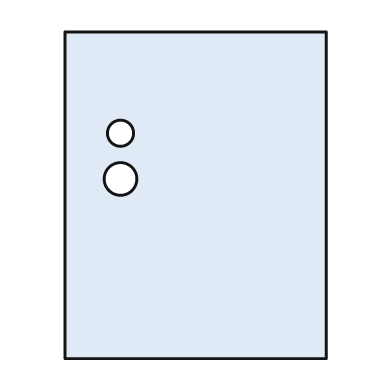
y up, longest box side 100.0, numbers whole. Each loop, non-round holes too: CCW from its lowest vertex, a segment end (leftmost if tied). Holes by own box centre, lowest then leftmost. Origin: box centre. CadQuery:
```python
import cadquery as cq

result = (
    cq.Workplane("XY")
    .moveTo(-40.0, -50.0)
    .lineTo(40.0, -50.0)
    .lineTo(40.0, 50.0)
    .lineTo(-40.0, 50.0)
    .close()
    .moveTo(-23.0, 5.0)
    .circle(5.0)
    .moveTo(-23.0, 19.0)
    .circle(4.0)
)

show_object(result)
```